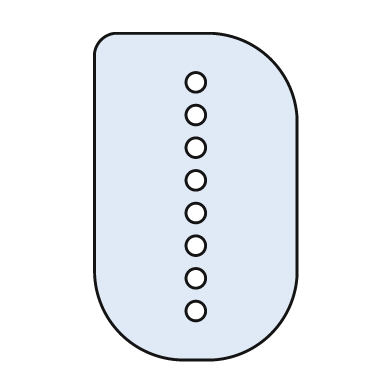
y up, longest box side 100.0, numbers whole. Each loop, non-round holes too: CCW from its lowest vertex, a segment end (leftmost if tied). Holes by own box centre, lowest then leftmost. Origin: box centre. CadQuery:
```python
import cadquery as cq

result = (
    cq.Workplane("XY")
    .moveTo(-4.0, -50.0)
    .lineTo(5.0, -50.0)
    .threePointArc((23.0, -42.0), (31.0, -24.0))
    .lineTo(31.0, 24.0)
    .threePointArc((23.0, 42.0), (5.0, 50.0))
    .lineTo(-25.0, 50.0)
    .threePointArc((-29.0, 48.0), (-31.0, 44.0))
    .lineTo(-31.0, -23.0)
    .threePointArc((-23.0, -42.0), (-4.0, -50.0))
    .close()
    .moveTo(0.0, -35.0)
    .circle(3.0)
    .moveTo(0.0, -25.0)
    .circle(3.0)
    .moveTo(0.0, -15.0)
    .circle(3.0)
    .moveTo(0.0, -5.0)
    .circle(3.0)
    .moveTo(0.0, 5.0)
    .circle(3.0)
    .moveTo(0.0, 15.0)
    .circle(3.0)
    .moveTo(0.0, 25.0)
    .circle(3.0)
    .moveTo(0.0, 35.0)
    .circle(3.0)
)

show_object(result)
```